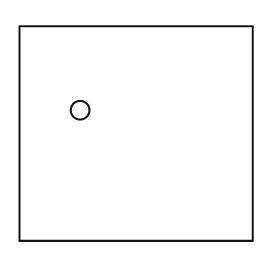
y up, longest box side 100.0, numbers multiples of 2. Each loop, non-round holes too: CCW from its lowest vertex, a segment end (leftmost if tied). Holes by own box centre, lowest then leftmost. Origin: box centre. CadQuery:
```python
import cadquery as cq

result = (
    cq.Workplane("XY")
    .moveTo(-50.0, -46.0)
    .lineTo(50.0, -46.0)
    .lineTo(50.0, 46.0)
    .lineTo(-50.0, 46.0)
    .close()
    .moveTo(-24.0, 10.0)
    .circle(4.0)
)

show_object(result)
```